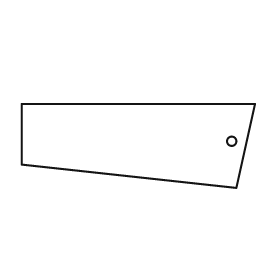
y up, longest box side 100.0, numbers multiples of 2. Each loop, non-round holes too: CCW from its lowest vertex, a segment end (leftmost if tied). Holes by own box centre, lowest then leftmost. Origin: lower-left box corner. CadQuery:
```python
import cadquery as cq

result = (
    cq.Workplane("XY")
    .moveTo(92.0, 0.0)
    .lineTo(100.0, 36.0)
    .lineTo(0.0, 36.0)
    .lineTo(0.0, 10.0)
    .close()
    .moveTo(90.0, 20.0)
    .circle(2.0)
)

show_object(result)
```